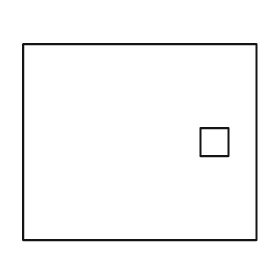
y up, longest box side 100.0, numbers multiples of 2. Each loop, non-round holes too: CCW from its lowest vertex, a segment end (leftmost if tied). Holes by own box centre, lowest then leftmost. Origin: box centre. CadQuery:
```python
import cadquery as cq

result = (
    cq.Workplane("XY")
    .moveTo(-50.0, -42.0)
    .lineTo(50.0, -42.0)
    .lineTo(50.0, 42.0)
    .lineTo(-50.0, 42.0)
    .close()
    .moveTo(26.0, -6.0)
    .lineTo(38.0, -6.0)
    .lineTo(38.0, 6.0)
    .lineTo(26.0, 6.0)
    .close()
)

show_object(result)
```